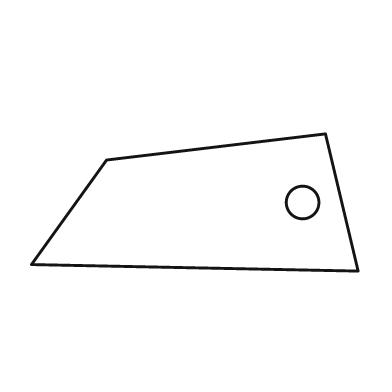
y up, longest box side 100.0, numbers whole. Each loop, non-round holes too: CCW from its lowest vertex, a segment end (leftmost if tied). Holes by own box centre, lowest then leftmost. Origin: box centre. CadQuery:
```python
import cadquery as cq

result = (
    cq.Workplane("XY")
    .moveTo(50.0, -21.0)
    .lineTo(40.0, 21.0)
    .lineTo(-27.0, 13.0)
    .lineTo(-50.0, -19.0)
    .close()
    .moveTo(33.0, 0.0)
    .circle(5.0)
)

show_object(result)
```